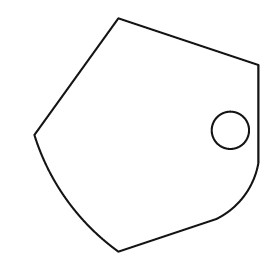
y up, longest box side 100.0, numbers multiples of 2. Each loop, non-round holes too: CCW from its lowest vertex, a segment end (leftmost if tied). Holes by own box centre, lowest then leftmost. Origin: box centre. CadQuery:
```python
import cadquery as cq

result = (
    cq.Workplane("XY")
    .moveTo(-12.0, -50.0)
    .lineTo(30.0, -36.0)
    .threePointArc((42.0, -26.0), (48.0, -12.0))
    .lineTo(48.0, 30.0)
    .lineTo(-12.0, 50.0)
    .lineTo(-48.0, 0.0)
    .threePointArc((-34.0, -28.0), (-12.0, -50.0))
    .close()
    .moveTo(36.0, 2.0)
    .circle(8.0)
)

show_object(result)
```